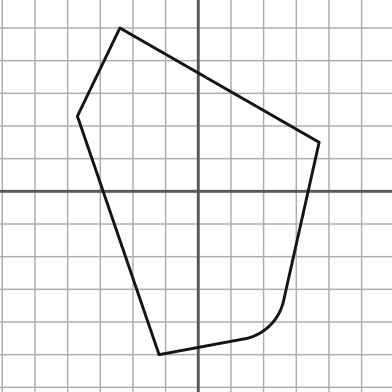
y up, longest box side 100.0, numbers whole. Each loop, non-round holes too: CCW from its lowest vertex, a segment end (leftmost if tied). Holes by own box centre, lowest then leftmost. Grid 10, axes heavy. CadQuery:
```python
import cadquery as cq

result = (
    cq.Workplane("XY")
    .moveTo(-12.0, -50.0)
    .lineTo(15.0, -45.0)
    .threePointArc((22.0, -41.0), (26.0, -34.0))
    .lineTo(37.0, 15.0)
    .lineTo(-24.0, 50.0)
    .lineTo(-37.0, 23.0)
    .close()
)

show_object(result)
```